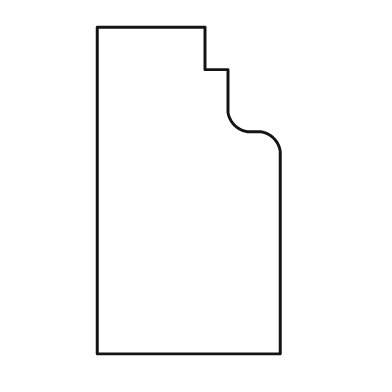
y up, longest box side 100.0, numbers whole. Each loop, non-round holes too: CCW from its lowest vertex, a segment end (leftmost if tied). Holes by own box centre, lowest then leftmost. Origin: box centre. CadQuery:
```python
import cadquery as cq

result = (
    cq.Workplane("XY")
    .moveTo(-28.0, -50.0)
    .lineTo(28.0, -50.0)
    .lineTo(28.0, 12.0)
    .threePointArc((26.0, 16.0), (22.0, 18.0))
    .lineTo(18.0, 18.0)
    .threePointArc((14.0, 20.0), (12.0, 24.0))
    .lineTo(12.0, 37.0)
    .lineTo(5.0, 37.0)
    .lineTo(5.0, 50.0)
    .lineTo(-28.0, 50.0)
    .close()
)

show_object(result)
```